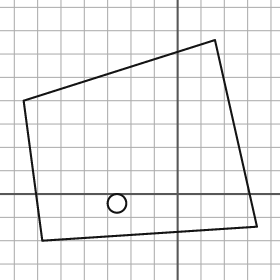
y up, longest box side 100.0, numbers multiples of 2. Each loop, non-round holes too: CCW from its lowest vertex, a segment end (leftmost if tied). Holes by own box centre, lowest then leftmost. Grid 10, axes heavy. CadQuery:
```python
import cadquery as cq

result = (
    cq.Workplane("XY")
    .moveTo(-58.0, -20.0)
    .lineTo(34.0, -14.0)
    .lineTo(16.0, 66.0)
    .lineTo(-66.0, 40.0)
    .close()
    .moveTo(-26.0, -4.0)
    .circle(4.0)
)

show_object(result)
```